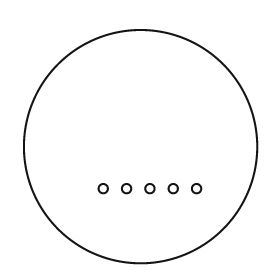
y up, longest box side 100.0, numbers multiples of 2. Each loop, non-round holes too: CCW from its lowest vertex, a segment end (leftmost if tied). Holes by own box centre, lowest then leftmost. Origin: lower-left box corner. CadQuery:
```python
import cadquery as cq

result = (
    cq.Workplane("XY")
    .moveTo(50.0, 50.0)
    .circle(50.0)
    .moveTo(34.0, 32.0)
    .circle(2.0)
    .moveTo(44.0, 32.0)
    .circle(2.0)
    .moveTo(54.0, 32.0)
    .circle(2.0)
    .moveTo(64.0, 32.0)
    .circle(2.0)
    .moveTo(74.0, 32.0)
    .circle(2.0)
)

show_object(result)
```